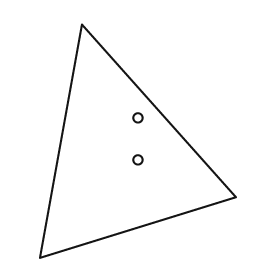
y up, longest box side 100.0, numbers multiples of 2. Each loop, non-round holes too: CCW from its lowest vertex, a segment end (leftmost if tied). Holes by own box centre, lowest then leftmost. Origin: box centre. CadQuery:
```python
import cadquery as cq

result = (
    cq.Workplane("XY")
    .moveTo(-42.0, -50.0)
    .lineTo(42.0, -24.0)
    .lineTo(-24.0, 50.0)
    .close()
    .moveTo(0.0, -8.0)
    .circle(2.0)
    .moveTo(0.0, 10.0)
    .circle(2.0)
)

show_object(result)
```